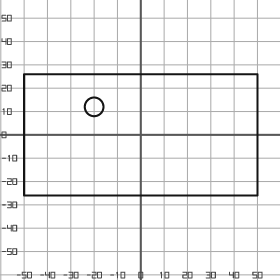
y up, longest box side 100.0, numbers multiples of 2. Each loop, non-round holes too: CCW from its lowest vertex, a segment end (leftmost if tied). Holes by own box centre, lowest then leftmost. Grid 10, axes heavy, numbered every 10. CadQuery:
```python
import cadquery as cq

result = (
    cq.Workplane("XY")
    .moveTo(-50.0, -26.0)
    .lineTo(50.0, -26.0)
    .lineTo(50.0, 26.0)
    .lineTo(-50.0, 26.0)
    .close()
    .moveTo(-20.0, 12.0)
    .circle(4.0)
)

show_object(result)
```